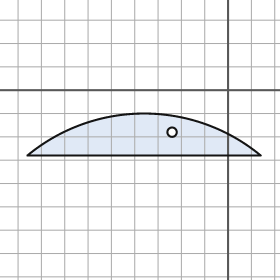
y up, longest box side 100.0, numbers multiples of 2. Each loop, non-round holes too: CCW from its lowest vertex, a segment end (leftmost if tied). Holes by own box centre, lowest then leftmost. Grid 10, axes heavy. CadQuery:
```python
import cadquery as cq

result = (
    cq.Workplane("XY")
    .moveTo(-86.0, -28.0)
    .lineTo(14.0, -28.0)
    .threePointArc((-36.0, -10.0), (-86.0, -28.0))
    .close()
    .moveTo(-24.0, -18.0)
    .circle(2.0)
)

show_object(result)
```